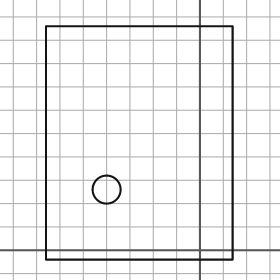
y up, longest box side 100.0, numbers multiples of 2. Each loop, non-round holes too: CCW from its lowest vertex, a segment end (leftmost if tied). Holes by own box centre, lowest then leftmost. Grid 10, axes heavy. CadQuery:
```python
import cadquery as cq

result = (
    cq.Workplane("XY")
    .moveTo(-66.0, -4.0)
    .lineTo(14.0, -4.0)
    .lineTo(14.0, 96.0)
    .lineTo(-66.0, 96.0)
    .close()
    .moveTo(-40.0, 26.0)
    .circle(6.0)
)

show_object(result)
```